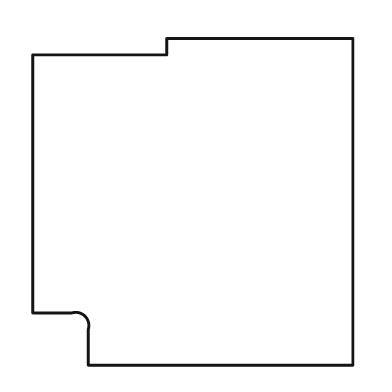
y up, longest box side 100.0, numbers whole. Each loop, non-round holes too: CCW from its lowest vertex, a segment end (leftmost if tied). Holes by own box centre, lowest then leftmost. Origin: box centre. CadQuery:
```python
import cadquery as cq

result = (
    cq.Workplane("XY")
    .moveTo(-32.0, -50.0)
    .lineTo(49.0, -50.0)
    .lineTo(49.0, 50.0)
    .lineTo(-8.0, 50.0)
    .lineTo(-8.0, 45.0)
    .lineTo(-49.0, 45.0)
    .lineTo(-49.0, -34.0)
    .lineTo(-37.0, -34.0)
    .threePointArc((-33.0, -35.0), (-32.0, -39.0))
    .close()
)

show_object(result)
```